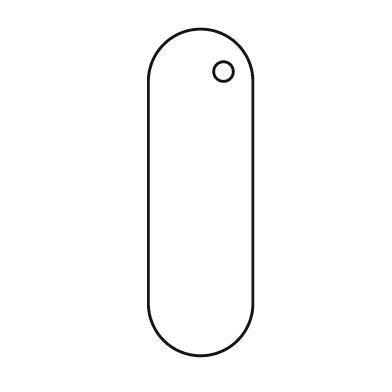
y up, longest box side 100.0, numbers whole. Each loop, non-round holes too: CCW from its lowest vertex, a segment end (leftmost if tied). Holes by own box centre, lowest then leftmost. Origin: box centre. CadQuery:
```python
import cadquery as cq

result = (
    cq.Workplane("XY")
    .moveTo(-16.0, -34.0)
    .threePointArc((0.0, -50.0), (16.0, -34.0))
    .lineTo(16.0, 34.0)
    .threePointArc((0.0, 50.0), (-16.0, 34.0))
    .close()
    .moveTo(7.0, 37.0)
    .circle(3.0)
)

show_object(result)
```